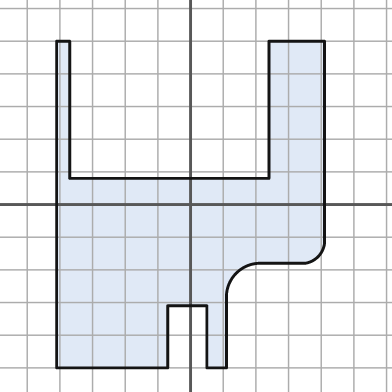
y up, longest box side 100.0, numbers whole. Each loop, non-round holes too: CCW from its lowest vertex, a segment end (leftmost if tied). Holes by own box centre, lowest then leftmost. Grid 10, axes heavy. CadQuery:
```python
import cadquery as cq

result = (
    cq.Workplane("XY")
    .moveTo(-41.0, -50.0)
    .lineTo(-7.0, -50.0)
    .lineTo(-7.0, -31.0)
    .lineTo(5.0, -31.0)
    .lineTo(5.0, -50.0)
    .lineTo(11.0, -50.0)
    .lineTo(11.0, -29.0)
    .threePointArc((14.0, -21.0), (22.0, -18.0))
    .lineTo(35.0, -18.0)
    .threePointArc((39.0, -16.0), (41.0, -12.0))
    .lineTo(41.0, 50.0)
    .lineTo(24.0, 50.0)
    .lineTo(24.0, 8.0)
    .lineTo(-37.0, 8.0)
    .lineTo(-37.0, 50.0)
    .lineTo(-41.0, 50.0)
    .close()
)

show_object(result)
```